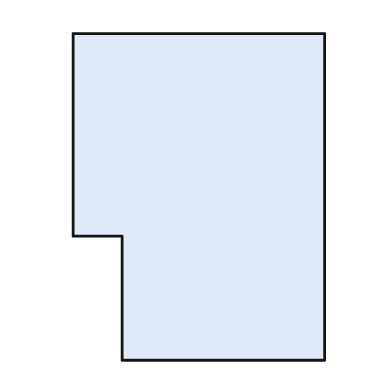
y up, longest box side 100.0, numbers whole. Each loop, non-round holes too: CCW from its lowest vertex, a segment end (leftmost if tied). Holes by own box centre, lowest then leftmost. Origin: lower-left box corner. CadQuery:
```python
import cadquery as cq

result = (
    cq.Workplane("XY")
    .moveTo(15.0, 0.0)
    .lineTo(77.0, 0.0)
    .lineTo(77.0, 100.0)
    .lineTo(0.0, 100.0)
    .lineTo(0.0, 38.0)
    .lineTo(15.0, 38.0)
    .close()
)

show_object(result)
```